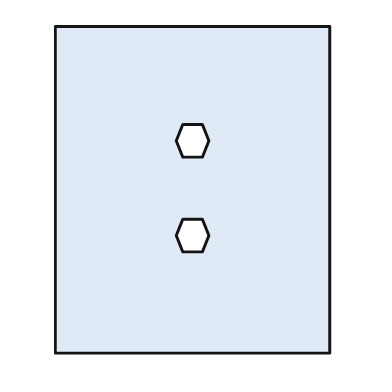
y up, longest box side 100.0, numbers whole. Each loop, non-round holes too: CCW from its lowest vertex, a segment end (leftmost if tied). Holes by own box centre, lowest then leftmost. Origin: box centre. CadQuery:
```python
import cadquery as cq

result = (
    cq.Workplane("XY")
    .moveTo(-42.0, -50.0)
    .lineTo(42.0, -50.0)
    .lineTo(42.0, 50.0)
    .lineTo(-42.0, 50.0)
    .close()
    .moveTo(-3.0, -19.0)
    .lineTo(3.0, -19.0)
    .lineTo(5.0, -14.0)
    .lineTo(3.0, -9.0)
    .lineTo(-3.0, -9.0)
    .lineTo(-5.0, -14.0)
    .close()
    .moveTo(-3.0, 10.0)
    .lineTo(3.0, 10.0)
    .lineTo(5.0, 15.0)
    .lineTo(3.0, 20.0)
    .lineTo(-3.0, 20.0)
    .lineTo(-5.0, 15.0)
    .close()
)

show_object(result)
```